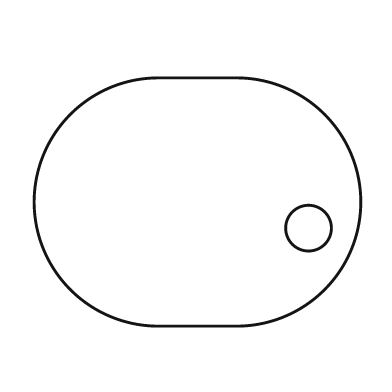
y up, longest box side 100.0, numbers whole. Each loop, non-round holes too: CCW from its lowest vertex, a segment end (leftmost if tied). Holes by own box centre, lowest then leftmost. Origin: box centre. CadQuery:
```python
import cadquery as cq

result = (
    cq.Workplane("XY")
    .moveTo(-12.0, -38.0)
    .lineTo(12.0, -38.0)
    .threePointArc((50.0, 0.0), (12.0, 38.0))
    .lineTo(-12.0, 38.0)
    .threePointArc((-50.0, 0.0), (-12.0, -38.0))
    .close()
    .moveTo(34.0, -8.0)
    .circle(7.0)
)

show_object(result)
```